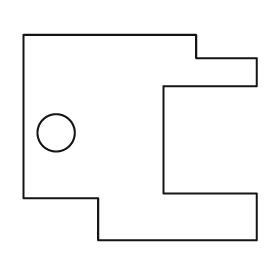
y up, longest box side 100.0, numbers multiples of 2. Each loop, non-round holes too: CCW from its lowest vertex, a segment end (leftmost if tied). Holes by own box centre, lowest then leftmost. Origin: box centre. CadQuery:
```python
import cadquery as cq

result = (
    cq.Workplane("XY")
    .moveTo(-18.0, -44.0)
    .lineTo(50.0, -44.0)
    .lineTo(50.0, -24.0)
    .lineTo(10.0, -24.0)
    .lineTo(10.0, 22.0)
    .lineTo(50.0, 22.0)
    .lineTo(50.0, 34.0)
    .lineTo(24.0, 34.0)
    .lineTo(24.0, 44.0)
    .lineTo(-50.0, 44.0)
    .lineTo(-50.0, -26.0)
    .lineTo(-18.0, -26.0)
    .close()
    .moveTo(-36.0, 2.0)
    .circle(8.0)
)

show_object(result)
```